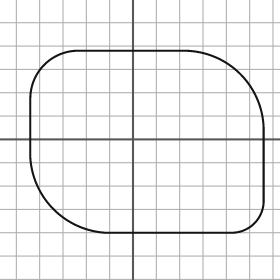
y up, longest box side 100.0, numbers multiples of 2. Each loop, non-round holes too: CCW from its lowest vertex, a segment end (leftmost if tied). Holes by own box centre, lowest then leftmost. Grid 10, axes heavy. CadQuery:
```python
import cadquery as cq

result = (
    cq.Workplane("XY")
    .moveTo(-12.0, -40.0)
    .lineTo(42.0, -40.0)
    .threePointArc((52.0, -36.0), (56.0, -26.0))
    .lineTo(56.0, 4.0)
    .threePointArc((46.0, 28.0), (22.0, 38.0))
    .lineTo(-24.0, 38.0)
    .threePointArc((-38.0, 32.0), (-44.0, 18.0))
    .lineTo(-44.0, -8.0)
    .threePointArc((-34.0, -30.0), (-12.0, -40.0))
    .close()
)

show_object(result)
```